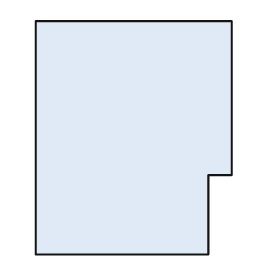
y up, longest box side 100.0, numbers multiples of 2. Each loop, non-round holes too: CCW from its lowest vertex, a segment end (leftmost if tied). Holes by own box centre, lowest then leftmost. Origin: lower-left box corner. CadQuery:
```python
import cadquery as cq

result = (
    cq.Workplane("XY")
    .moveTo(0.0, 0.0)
    .lineTo(74.0, 0.0)
    .lineTo(74.0, 34.0)
    .lineTo(84.0, 34.0)
    .lineTo(84.0, 100.0)
    .lineTo(0.0, 100.0)
    .close()
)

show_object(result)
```